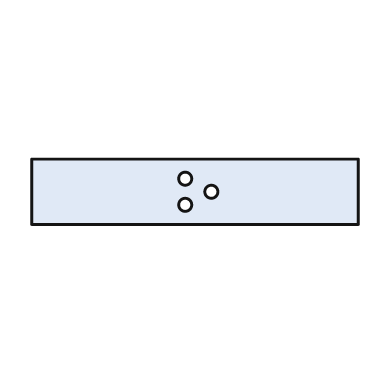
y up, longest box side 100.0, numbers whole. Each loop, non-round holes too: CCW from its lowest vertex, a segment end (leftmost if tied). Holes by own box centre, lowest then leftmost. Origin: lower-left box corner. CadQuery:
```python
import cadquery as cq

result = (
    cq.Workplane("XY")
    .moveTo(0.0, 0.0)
    .lineTo(100.0, 0.0)
    .lineTo(100.0, 20.0)
    .lineTo(0.0, 20.0)
    .close()
    .moveTo(47.0, 6.0)
    .circle(2.0)
    .moveTo(55.0, 10.0)
    .circle(2.0)
    .moveTo(47.0, 14.0)
    .circle(2.0)
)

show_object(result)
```